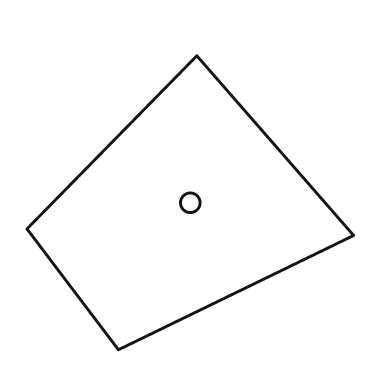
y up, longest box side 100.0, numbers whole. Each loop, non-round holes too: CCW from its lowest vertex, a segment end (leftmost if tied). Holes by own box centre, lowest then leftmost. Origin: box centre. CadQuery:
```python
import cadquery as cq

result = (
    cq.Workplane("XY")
    .moveTo(-22.0, -45.0)
    .lineTo(50.0, -10.0)
    .lineTo(2.0, 45.0)
    .lineTo(-50.0, -8.0)
    .close()
    .moveTo(0.0, 0.0)
    .circle(3.0)
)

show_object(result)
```